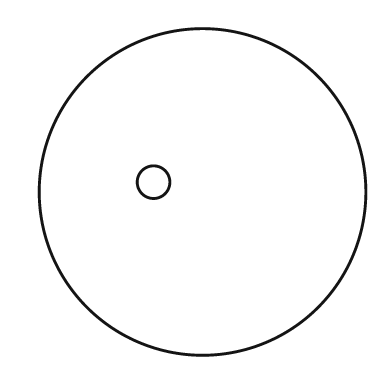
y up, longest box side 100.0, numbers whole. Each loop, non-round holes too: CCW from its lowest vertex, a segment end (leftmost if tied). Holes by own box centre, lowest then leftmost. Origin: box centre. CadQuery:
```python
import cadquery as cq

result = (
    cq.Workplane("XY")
    .moveTo(0.0, 0.0)
    .circle(50.0)
    .moveTo(-15.0, 3.0)
    .circle(5.0)
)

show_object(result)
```